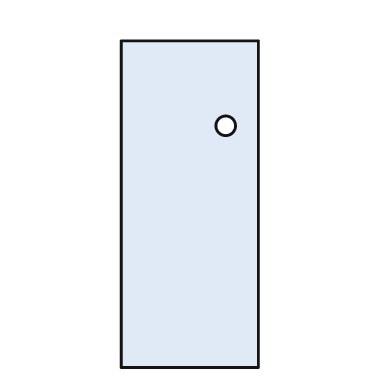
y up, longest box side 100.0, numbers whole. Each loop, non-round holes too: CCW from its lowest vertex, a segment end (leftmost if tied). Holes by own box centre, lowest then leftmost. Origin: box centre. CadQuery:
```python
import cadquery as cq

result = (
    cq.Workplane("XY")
    .moveTo(-21.0, -50.0)
    .lineTo(21.0, -50.0)
    .lineTo(21.0, 50.0)
    .lineTo(-21.0, 50.0)
    .close()
    .moveTo(11.0, 24.0)
    .circle(3.0)
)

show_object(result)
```